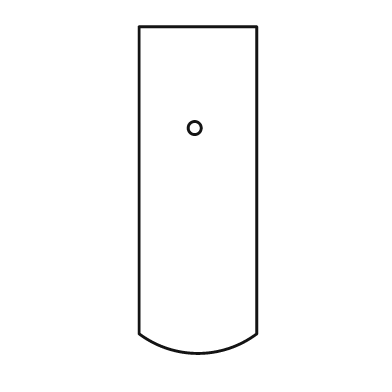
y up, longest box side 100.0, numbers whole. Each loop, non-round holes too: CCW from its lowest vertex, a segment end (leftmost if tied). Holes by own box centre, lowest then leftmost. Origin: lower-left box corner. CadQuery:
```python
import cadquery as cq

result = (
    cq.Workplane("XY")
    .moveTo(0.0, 6.0)
    .threePointArc((18.0, 0.0), (36.0, 6.0))
    .lineTo(36.0, 100.0)
    .lineTo(0.0, 100.0)
    .close()
    .moveTo(17.0, 69.0)
    .circle(2.0)
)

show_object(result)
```